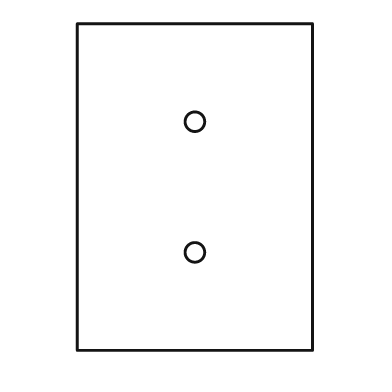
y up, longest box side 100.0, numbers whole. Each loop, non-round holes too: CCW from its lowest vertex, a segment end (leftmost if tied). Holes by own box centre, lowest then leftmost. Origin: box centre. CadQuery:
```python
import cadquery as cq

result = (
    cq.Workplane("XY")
    .moveTo(-36.0, -50.0)
    .lineTo(36.0, -50.0)
    .lineTo(36.0, 50.0)
    .lineTo(-36.0, 50.0)
    .close()
    .moveTo(0.0, -20.0)
    .circle(3.0)
    .moveTo(0.0, 20.0)
    .circle(3.0)
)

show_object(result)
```